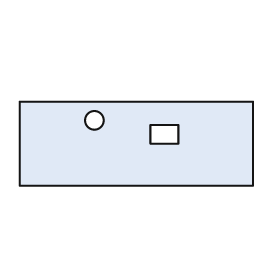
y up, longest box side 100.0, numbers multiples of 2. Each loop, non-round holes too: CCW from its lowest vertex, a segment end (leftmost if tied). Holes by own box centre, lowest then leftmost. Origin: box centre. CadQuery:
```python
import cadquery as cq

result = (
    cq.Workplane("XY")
    .moveTo(-50.0, -18.0)
    .lineTo(50.0, -18.0)
    .lineTo(50.0, 18.0)
    .lineTo(-50.0, 18.0)
    .close()
    .moveTo(6.0, 0.0)
    .lineTo(18.0, 0.0)
    .lineTo(18.0, 8.0)
    .lineTo(6.0, 8.0)
    .close()
    .moveTo(-18.0, 10.0)
    .circle(4.0)
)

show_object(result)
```